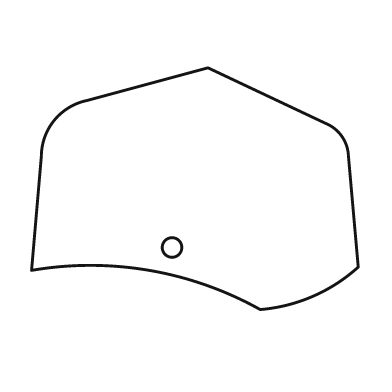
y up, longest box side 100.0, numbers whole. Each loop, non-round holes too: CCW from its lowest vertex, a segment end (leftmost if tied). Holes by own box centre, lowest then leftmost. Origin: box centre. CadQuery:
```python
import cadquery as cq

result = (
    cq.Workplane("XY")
    .moveTo(20.0, -37.0)
    .threePointArc((36.0, -33.0), (50.0, -24.0))
    .lineTo(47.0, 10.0)
    .threePointArc((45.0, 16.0), (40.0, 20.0))
    .lineTo(4.0, 37.0)
    .lineTo(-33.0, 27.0)
    .threePointArc((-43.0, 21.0), (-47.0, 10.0))
    .lineTo(-50.0, -25.0)
    .threePointArc((-14.0, -25.0), (20.0, -37.0))
    .close()
    .moveTo(-7.0, -18.0)
    .circle(3.0)
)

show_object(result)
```